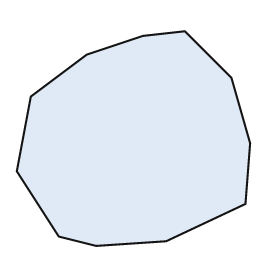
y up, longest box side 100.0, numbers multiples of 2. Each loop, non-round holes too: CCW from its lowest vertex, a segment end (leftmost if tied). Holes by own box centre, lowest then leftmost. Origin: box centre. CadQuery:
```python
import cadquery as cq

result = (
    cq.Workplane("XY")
    .moveTo(-16.0, -46.0)
    .lineTo(14.0, -44.0)
    .lineTo(48.0, -28.0)
    .lineTo(50.0, -2.0)
    .lineTo(42.0, 26.0)
    .lineTo(22.0, 46.0)
    .lineTo(4.0, 44.0)
    .lineTo(-20.0, 36.0)
    .lineTo(-44.0, 18.0)
    .lineTo(-50.0, -14.0)
    .lineTo(-32.0, -42.0)
    .close()
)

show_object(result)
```